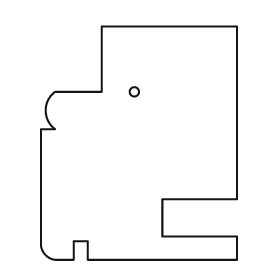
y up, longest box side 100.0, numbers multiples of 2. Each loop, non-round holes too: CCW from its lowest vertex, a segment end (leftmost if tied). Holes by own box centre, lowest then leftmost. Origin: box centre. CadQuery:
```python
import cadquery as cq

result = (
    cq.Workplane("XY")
    .moveTo(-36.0, -50.0)
    .lineTo(-28.0, -50.0)
    .lineTo(-28.0, -42.0)
    .lineTo(-22.0, -42.0)
    .lineTo(-22.0, -50.0)
    .lineTo(42.0, -50.0)
    .lineTo(42.0, -40.0)
    .lineTo(10.0, -40.0)
    .lineTo(10.0, -24.0)
    .lineTo(42.0, -24.0)
    .lineTo(42.0, 50.0)
    .lineTo(-16.0, 50.0)
    .lineTo(-16.0, 22.0)
    .lineTo(-36.0, 22.0)
    .threePointArc((-40.0, 14.0), (-36.0, 6.0))
    .lineTo(-42.0, 6.0)
    .lineTo(-42.0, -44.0)
    .threePointArc((-40.0, -48.0), (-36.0, -50.0))
    .close()
    .moveTo(-2.0, 22.0)
    .circle(2.0)
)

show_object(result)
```